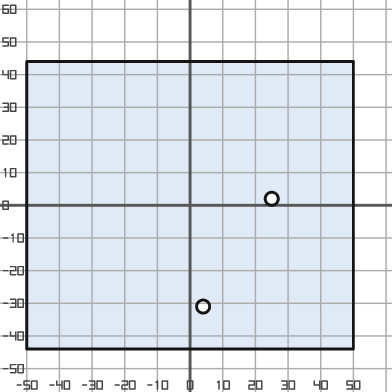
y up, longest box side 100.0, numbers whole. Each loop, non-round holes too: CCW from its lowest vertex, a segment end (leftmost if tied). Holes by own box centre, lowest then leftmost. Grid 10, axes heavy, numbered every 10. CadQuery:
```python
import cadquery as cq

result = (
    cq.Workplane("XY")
    .moveTo(-50.0, -44.0)
    .lineTo(50.0, -44.0)
    .lineTo(50.0, 44.0)
    .lineTo(-50.0, 44.0)
    .close()
    .moveTo(4.0, -31.0)
    .circle(2.0)
    .moveTo(25.0, 2.0)
    .circle(2.0)
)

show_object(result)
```